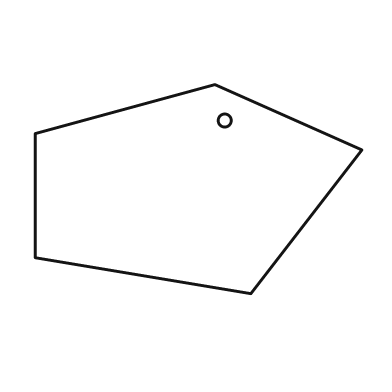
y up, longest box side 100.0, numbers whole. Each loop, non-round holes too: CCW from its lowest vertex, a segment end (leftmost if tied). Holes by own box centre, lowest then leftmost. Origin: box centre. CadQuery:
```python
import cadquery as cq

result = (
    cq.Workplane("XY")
    .moveTo(16.0, -32.0)
    .lineTo(50.0, 12.0)
    .lineTo(5.0, 32.0)
    .lineTo(-50.0, 17.0)
    .lineTo(-50.0, -21.0)
    .close()
    .moveTo(8.0, 21.0)
    .circle(2.0)
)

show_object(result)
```